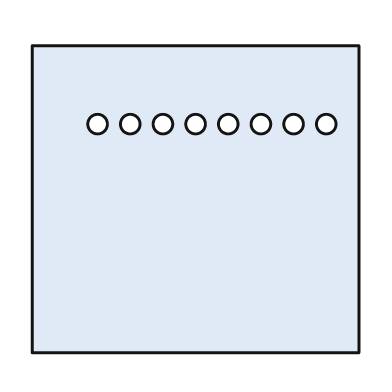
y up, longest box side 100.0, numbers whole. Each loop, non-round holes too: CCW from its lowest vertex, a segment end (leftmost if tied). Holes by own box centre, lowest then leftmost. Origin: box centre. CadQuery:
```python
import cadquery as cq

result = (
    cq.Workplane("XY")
    .moveTo(-50.0, -47.0)
    .lineTo(50.0, -47.0)
    .lineTo(50.0, 47.0)
    .lineTo(-50.0, 47.0)
    .close()
    .moveTo(-30.0, 23.0)
    .circle(3.0)
    .moveTo(-20.0, 23.0)
    .circle(3.0)
    .moveTo(-10.0, 23.0)
    .circle(3.0)
    .moveTo(0.0, 23.0)
    .circle(3.0)
    .moveTo(10.0, 23.0)
    .circle(3.0)
    .moveTo(20.0, 23.0)
    .circle(3.0)
    .moveTo(30.0, 23.0)
    .circle(3.0)
    .moveTo(40.0, 23.0)
    .circle(3.0)
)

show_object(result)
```